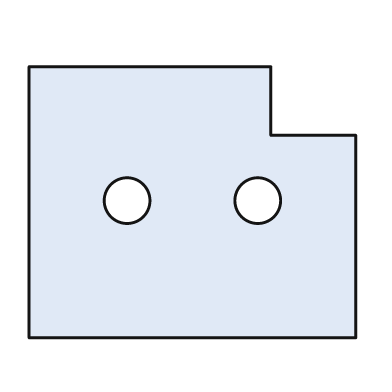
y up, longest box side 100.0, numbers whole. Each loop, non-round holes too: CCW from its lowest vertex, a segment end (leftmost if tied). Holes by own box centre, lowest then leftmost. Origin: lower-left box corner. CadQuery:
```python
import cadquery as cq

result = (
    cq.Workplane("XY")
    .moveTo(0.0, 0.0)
    .lineTo(100.0, 0.0)
    .lineTo(100.0, 62.0)
    .lineTo(74.0, 62.0)
    .lineTo(74.0, 83.0)
    .lineTo(0.0, 83.0)
    .close()
    .moveTo(30.0, 42.0)
    .circle(7.0)
    .moveTo(70.0, 42.0)
    .circle(7.0)
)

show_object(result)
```